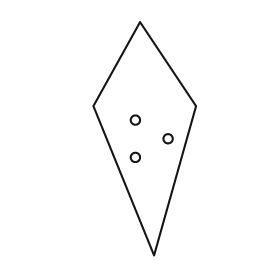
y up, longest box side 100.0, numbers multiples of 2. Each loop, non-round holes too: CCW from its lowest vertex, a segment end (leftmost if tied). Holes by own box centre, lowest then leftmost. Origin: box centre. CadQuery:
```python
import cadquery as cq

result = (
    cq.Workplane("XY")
    .moveTo(4.0, -50.0)
    .lineTo(22.0, 14.0)
    .lineTo(-2.0, 50.0)
    .lineTo(-22.0, 14.0)
    .close()
    .moveTo(-4.0, -8.0)
    .circle(2.0)
    .moveTo(10.0, 0.0)
    .circle(2.0)
    .moveTo(-4.0, 8.0)
    .circle(2.0)
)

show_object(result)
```